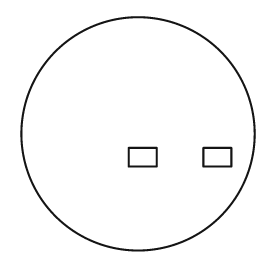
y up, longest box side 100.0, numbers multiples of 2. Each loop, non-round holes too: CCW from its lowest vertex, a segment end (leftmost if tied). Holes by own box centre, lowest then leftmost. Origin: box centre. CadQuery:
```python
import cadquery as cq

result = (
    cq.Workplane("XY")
    .moveTo(0.0, 0.0)
    .circle(50.0)
    .moveTo(-4.0, -14.0)
    .lineTo(8.0, -14.0)
    .lineTo(8.0, -6.0)
    .lineTo(-4.0, -6.0)
    .close()
    .moveTo(28.0, -14.0)
    .lineTo(40.0, -14.0)
    .lineTo(40.0, -6.0)
    .lineTo(28.0, -6.0)
    .close()
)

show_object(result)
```